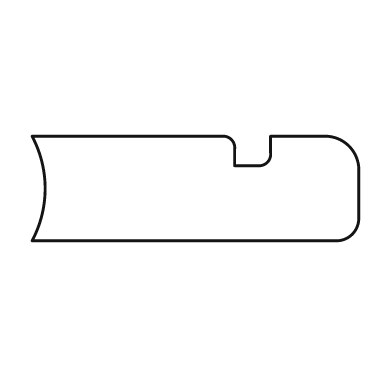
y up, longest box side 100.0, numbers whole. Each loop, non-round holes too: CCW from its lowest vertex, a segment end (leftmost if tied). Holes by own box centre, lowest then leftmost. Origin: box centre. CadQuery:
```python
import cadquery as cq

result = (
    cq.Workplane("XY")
    .moveTo(-50.0, -16.0)
    .lineTo(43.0, -16.0)
    .threePointArc((48.0, -14.0), (50.0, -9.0))
    .lineTo(50.0, 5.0)
    .threePointArc((47.0, 13.0), (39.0, 16.0))
    .lineTo(23.0, 16.0)
    .lineTo(23.0, 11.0)
    .threePointArc((22.0, 8.0), (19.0, 7.0))
    .lineTo(12.0, 7.0)
    .lineTo(12.0, 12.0)
    .threePointArc((11.0, 15.0), (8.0, 16.0))
    .lineTo(-50.0, 16.0)
    .threePointArc((-46.0, 0.0), (-50.0, -16.0))
    .close()
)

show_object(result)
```